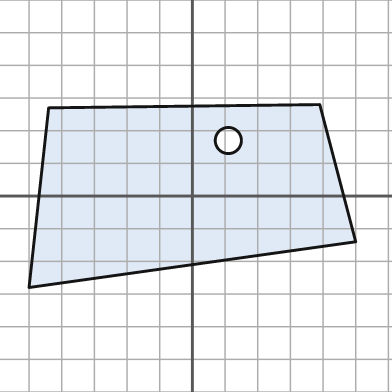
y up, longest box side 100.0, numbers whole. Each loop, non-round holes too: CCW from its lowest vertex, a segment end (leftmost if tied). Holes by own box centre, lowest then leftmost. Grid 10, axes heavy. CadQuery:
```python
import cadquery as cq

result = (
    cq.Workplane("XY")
    .moveTo(-50.0, -28.0)
    .lineTo(50.0, -14.0)
    .lineTo(39.0, 28.0)
    .lineTo(-44.0, 27.0)
    .close()
    .moveTo(11.0, 17.0)
    .circle(4.0)
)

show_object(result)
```